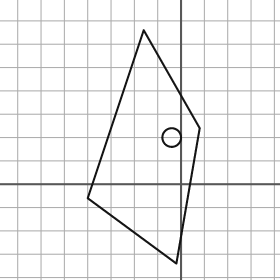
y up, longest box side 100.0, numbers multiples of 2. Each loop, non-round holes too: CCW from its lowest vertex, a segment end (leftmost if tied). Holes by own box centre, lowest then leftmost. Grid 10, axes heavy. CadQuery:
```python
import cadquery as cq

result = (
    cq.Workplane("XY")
    .moveTo(-2.0, -34.0)
    .lineTo(8.0, 24.0)
    .lineTo(-16.0, 66.0)
    .lineTo(-40.0, -6.0)
    .close()
    .moveTo(-4.0, 20.0)
    .circle(4.0)
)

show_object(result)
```